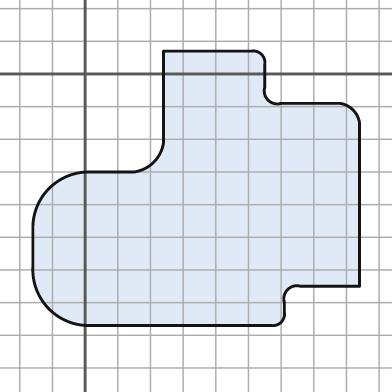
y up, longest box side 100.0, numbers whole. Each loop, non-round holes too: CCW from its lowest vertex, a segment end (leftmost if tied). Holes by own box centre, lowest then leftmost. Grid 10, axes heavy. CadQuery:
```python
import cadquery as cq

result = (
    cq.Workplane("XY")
    .moveTo(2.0, -77.0)
    .lineTo(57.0, -77.0)
    .threePointArc((60.0, -76.0), (61.0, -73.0))
    .lineTo(61.0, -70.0)
    .threePointArc((62.0, -66.0), (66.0, -65.0))
    .lineTo(84.0, -65.0)
    .lineTo(84.0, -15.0)
    .threePointArc((82.0, -11.0), (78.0, -9.0))
    .lineTo(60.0, -9.0)
    .threePointArc((56.0, -8.0), (55.0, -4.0))
    .lineTo(55.0, 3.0)
    .threePointArc((54.0, 6.0), (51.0, 7.0))
    .lineTo(24.0, 7.0)
    .lineTo(24.0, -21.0)
    .threePointArc((21.0, -27.0), (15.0, -30.0))
    .lineTo(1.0, -30.0)
    .threePointArc((-11.0, -35.0), (-16.0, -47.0))
    .lineTo(-16.0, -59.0)
    .threePointArc((-11.0, -72.0), (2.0, -77.0))
    .close()
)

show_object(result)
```